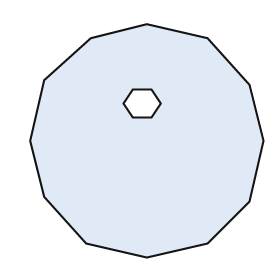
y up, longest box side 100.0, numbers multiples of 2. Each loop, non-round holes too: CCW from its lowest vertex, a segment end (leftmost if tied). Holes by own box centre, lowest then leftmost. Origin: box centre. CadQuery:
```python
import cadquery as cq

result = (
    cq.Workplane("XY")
    .moveTo(0.0, -50.0)
    .lineTo(26.0, -44.0)
    .lineTo(44.0, -26.0)
    .lineTo(50.0, 0.0)
    .lineTo(44.0, 24.0)
    .lineTo(26.0, 44.0)
    .lineTo(0.0, 50.0)
    .lineTo(-24.0, 44.0)
    .lineTo(-44.0, 26.0)
    .lineTo(-50.0, 0.0)
    .lineTo(-44.0, -24.0)
    .lineTo(-26.0, -44.0)
    .close()
    .moveTo(-6.0, 10.0)
    .lineTo(2.0, 10.0)
    .lineTo(6.0, 16.0)
    .lineTo(2.0, 22.0)
    .lineTo(-6.0, 22.0)
    .lineTo(-10.0, 16.0)
    .close()
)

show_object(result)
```